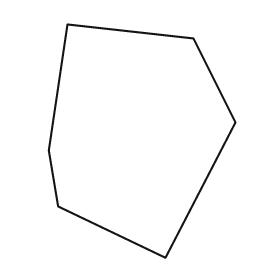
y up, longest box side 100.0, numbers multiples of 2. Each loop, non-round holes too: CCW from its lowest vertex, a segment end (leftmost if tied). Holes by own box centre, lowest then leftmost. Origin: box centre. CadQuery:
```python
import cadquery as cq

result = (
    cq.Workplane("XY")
    .moveTo(10.0, -50.0)
    .lineTo(40.0, 8.0)
    .lineTo(22.0, 44.0)
    .lineTo(-32.0, 50.0)
    .lineTo(-40.0, -4.0)
    .lineTo(-36.0, -28.0)
    .close()
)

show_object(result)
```